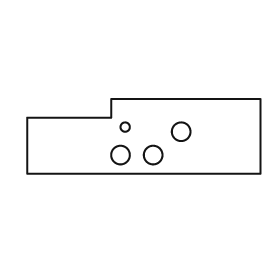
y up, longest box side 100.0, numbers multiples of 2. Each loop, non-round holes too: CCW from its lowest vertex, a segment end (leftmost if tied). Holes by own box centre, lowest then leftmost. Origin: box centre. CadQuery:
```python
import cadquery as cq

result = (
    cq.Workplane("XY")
    .moveTo(-50.0, -16.0)
    .lineTo(50.0, -16.0)
    .lineTo(50.0, 16.0)
    .lineTo(-14.0, 16.0)
    .lineTo(-14.0, 8.0)
    .lineTo(-50.0, 8.0)
    .close()
    .moveTo(-10.0, -8.0)
    .circle(4.0)
    .moveTo(4.0, -8.0)
    .circle(4.0)
    .moveTo(16.0, 2.0)
    .circle(4.0)
    .moveTo(-8.0, 4.0)
    .circle(2.0)
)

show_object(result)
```